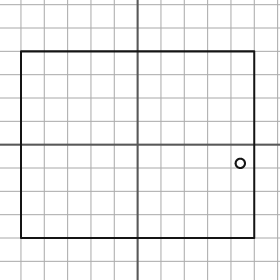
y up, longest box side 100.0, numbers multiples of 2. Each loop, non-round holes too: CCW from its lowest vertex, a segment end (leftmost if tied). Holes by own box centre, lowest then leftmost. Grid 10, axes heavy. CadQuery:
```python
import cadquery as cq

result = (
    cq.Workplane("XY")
    .moveTo(-50.0, -40.0)
    .lineTo(50.0, -40.0)
    .lineTo(50.0, 40.0)
    .lineTo(-50.0, 40.0)
    .close()
    .moveTo(44.0, -8.0)
    .circle(2.0)
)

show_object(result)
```